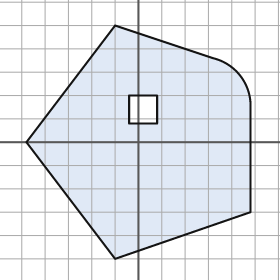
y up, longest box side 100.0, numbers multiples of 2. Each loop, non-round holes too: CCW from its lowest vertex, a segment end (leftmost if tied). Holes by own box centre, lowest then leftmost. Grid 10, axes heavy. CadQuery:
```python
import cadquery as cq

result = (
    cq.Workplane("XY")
    .moveTo(-10.0, -50.0)
    .lineTo(48.0, -30.0)
    .lineTo(48.0, 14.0)
    .threePointArc((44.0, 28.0), (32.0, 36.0))
    .lineTo(-10.0, 50.0)
    .lineTo(-48.0, 0.0)
    .close()
    .moveTo(-4.0, 8.0)
    .lineTo(8.0, 8.0)
    .lineTo(8.0, 20.0)
    .lineTo(-4.0, 20.0)
    .close()
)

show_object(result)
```